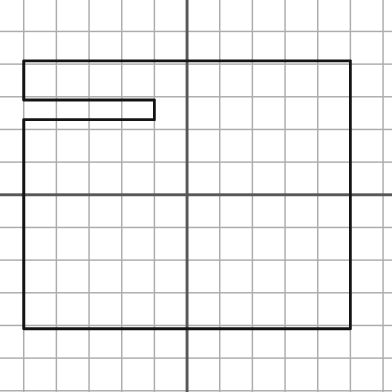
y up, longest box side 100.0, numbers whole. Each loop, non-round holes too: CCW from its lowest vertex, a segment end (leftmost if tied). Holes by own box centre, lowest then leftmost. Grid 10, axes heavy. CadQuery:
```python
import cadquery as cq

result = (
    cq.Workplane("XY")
    .moveTo(-50.0, -41.0)
    .lineTo(50.0, -41.0)
    .lineTo(50.0, 41.0)
    .lineTo(-50.0, 41.0)
    .lineTo(-50.0, 29.0)
    .lineTo(-10.0, 29.0)
    .lineTo(-10.0, 23.0)
    .lineTo(-50.0, 23.0)
    .close()
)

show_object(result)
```